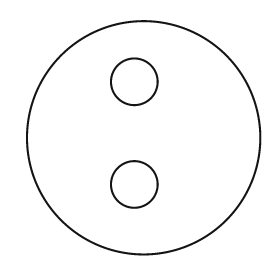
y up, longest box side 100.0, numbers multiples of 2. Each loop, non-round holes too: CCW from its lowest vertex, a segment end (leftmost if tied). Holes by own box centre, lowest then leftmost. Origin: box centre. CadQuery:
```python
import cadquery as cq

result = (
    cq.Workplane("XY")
    .moveTo(0.0, 0.0)
    .circle(50.0)
    .moveTo(-4.0, -20.0)
    .circle(10.0)
    .moveTo(-4.0, 24.0)
    .circle(10.0)
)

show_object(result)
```